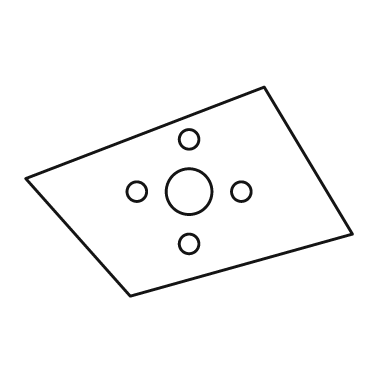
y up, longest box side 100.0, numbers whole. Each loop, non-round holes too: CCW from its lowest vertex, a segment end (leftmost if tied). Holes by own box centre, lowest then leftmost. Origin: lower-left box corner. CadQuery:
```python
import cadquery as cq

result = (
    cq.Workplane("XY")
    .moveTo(32.0, 0.0)
    .lineTo(100.0, 19.0)
    .lineTo(73.0, 64.0)
    .lineTo(0.0, 36.0)
    .close()
    .moveTo(50.0, 16.0)
    .circle(3.0)
    .moveTo(34.0, 32.0)
    .circle(3.0)
    .moveTo(50.0, 32.0)
    .circle(7.0)
    .moveTo(66.0, 32.0)
    .circle(3.0)
    .moveTo(50.0, 48.0)
    .circle(3.0)
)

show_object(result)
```